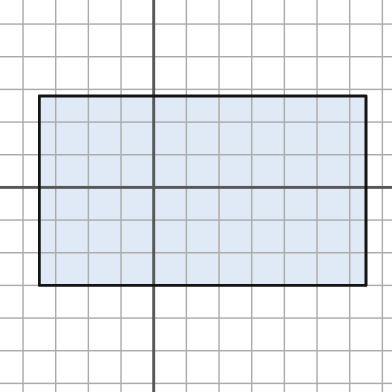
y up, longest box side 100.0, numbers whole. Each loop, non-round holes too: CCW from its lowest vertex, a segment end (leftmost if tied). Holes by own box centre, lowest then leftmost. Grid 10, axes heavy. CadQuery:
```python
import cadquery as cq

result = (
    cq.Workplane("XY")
    .moveTo(-35.0, -30.0)
    .lineTo(65.0, -30.0)
    .lineTo(65.0, 28.0)
    .lineTo(-35.0, 28.0)
    .close()
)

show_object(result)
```